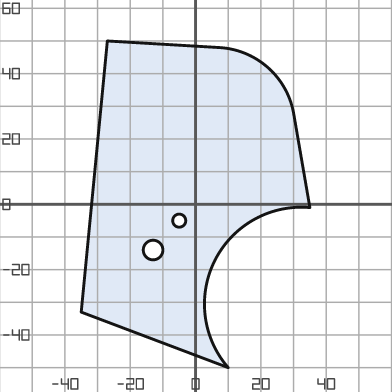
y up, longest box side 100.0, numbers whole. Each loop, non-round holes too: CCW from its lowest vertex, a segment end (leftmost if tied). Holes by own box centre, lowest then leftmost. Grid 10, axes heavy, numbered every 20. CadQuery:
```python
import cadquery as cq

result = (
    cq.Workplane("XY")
    .moveTo(10.0, -50.0)
    .threePointArc((6.0, -17.0), (35.0, -1.0))
    .lineTo(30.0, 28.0)
    .threePointArc((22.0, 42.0), (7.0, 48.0))
    .lineTo(-27.0, 50.0)
    .lineTo(-35.0, -33.0)
    .close()
    .moveTo(-13.0, -14.0)
    .circle(3.0)
    .moveTo(-5.0, -5.0)
    .circle(2.0)
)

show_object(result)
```